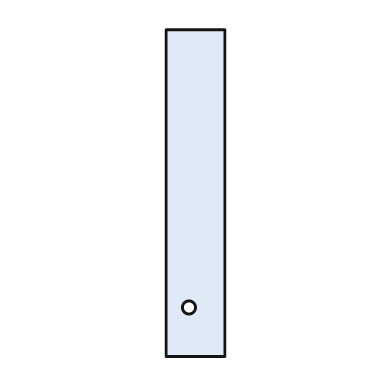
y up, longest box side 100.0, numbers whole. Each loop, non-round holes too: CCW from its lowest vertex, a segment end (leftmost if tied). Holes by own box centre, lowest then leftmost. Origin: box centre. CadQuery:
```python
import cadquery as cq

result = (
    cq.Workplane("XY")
    .moveTo(-9.0, -50.0)
    .lineTo(9.0, -50.0)
    .lineTo(9.0, 50.0)
    .lineTo(-9.0, 50.0)
    .close()
    .moveTo(-2.0, -35.0)
    .circle(2.0)
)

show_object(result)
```